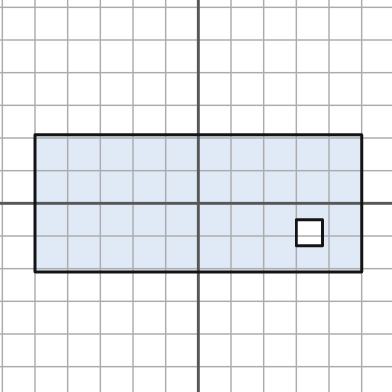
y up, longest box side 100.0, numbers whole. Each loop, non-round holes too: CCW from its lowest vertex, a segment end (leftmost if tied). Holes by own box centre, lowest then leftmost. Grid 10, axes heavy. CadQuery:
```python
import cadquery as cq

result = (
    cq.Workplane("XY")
    .moveTo(-50.0, -21.0)
    .lineTo(50.0, -21.0)
    .lineTo(50.0, 21.0)
    .lineTo(-50.0, 21.0)
    .close()
    .moveTo(30.0, -13.0)
    .lineTo(38.0, -13.0)
    .lineTo(38.0, -5.0)
    .lineTo(30.0, -5.0)
    .close()
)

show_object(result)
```